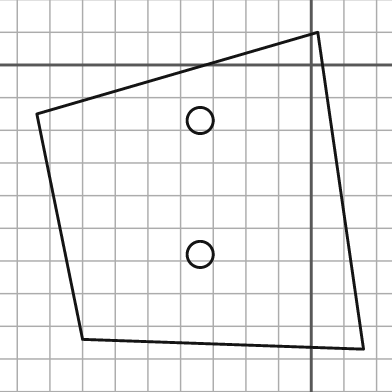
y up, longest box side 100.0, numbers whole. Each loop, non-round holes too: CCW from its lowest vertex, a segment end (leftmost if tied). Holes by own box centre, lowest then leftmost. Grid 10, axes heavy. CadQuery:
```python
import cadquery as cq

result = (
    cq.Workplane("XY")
    .moveTo(16.0, -87.0)
    .lineTo(2.0, 10.0)
    .lineTo(-84.0, -15.0)
    .lineTo(-70.0, -84.0)
    .close()
    .moveTo(-34.0, -58.0)
    .circle(4.0)
    .moveTo(-34.0, -17.0)
    .circle(4.0)
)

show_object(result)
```